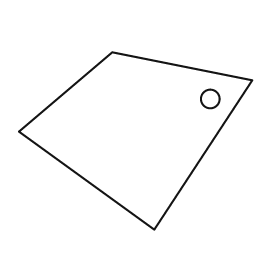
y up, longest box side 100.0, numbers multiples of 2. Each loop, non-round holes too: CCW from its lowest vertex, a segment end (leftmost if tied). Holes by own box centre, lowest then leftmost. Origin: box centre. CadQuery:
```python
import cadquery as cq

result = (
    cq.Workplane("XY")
    .moveTo(8.0, -38.0)
    .lineTo(50.0, 26.0)
    .lineTo(-10.0, 38.0)
    .lineTo(-50.0, 4.0)
    .close()
    .moveTo(32.0, 18.0)
    .circle(4.0)
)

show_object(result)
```